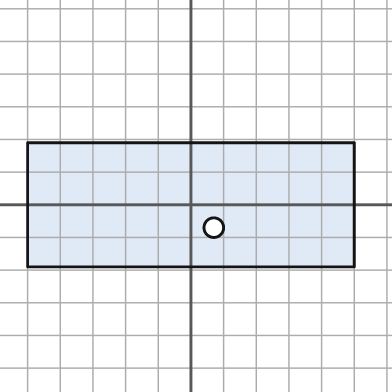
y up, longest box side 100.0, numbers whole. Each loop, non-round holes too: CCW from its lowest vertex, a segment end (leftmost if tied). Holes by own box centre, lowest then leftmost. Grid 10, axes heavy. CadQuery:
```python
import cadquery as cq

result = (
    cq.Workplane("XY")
    .moveTo(-50.0, -19.0)
    .lineTo(50.0, -19.0)
    .lineTo(50.0, 19.0)
    .lineTo(-50.0, 19.0)
    .close()
    .moveTo(7.0, -7.0)
    .circle(3.0)
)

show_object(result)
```